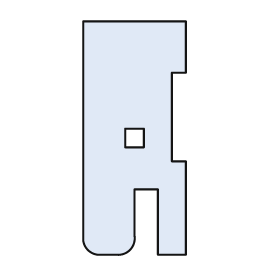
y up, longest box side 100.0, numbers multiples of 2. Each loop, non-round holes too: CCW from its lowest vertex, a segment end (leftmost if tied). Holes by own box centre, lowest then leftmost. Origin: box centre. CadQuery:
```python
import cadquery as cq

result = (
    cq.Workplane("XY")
    .moveTo(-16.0, -50.0)
    .lineTo(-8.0, -50.0)
    .threePointArc((-2.0, -48.0), (0.0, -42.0))
    .lineTo(0.0, -22.0)
    .lineTo(10.0, -22.0)
    .lineTo(10.0, -50.0)
    .lineTo(22.0, -50.0)
    .lineTo(22.0, -10.0)
    .lineTo(16.0, -10.0)
    .lineTo(16.0, 28.0)
    .lineTo(22.0, 28.0)
    .lineTo(22.0, 50.0)
    .lineTo(-22.0, 50.0)
    .lineTo(-22.0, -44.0)
    .threePointArc((-20.0, -48.0), (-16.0, -50.0))
    .close()
    .moveTo(-4.0, -4.0)
    .lineTo(4.0, -4.0)
    .lineTo(4.0, 4.0)
    .lineTo(-4.0, 4.0)
    .close()
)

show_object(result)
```